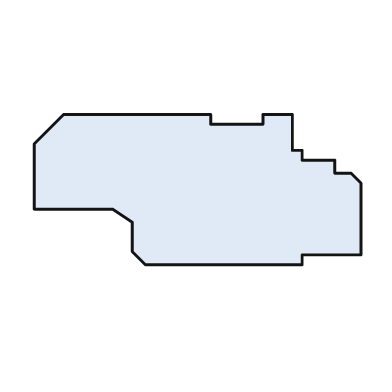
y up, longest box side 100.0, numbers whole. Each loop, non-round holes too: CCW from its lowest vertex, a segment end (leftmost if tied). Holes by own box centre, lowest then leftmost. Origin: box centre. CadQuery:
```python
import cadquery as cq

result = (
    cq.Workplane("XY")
    .moveTo(-16.0, -23.0)
    .lineTo(32.0, -23.0)
    .lineTo(32.0, -20.0)
    .lineTo(50.0, -20.0)
    .lineTo(50.0, 2.0)
    .lineTo(47.0, 5.0)
    .lineTo(42.0, 5.0)
    .lineTo(42.0, 9.0)
    .lineTo(32.0, 9.0)
    .lineTo(32.0, 12.0)
    .lineTo(29.0, 12.0)
    .lineTo(29.0, 23.0)
    .lineTo(20.0, 23.0)
    .lineTo(20.0, 20.0)
    .lineTo(4.0, 20.0)
    .lineTo(4.0, 23.0)
    .lineTo(-41.0, 23.0)
    .lineTo(-50.0, 14.0)
    .lineTo(-50.0, -6.0)
    .lineTo(-26.0, -6.0)
    .lineTo(-20.0, -10.0)
    .lineTo(-20.0, -19.0)
    .close()
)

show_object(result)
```